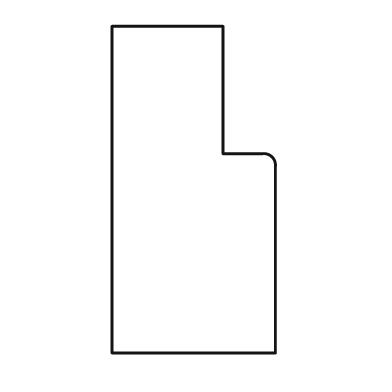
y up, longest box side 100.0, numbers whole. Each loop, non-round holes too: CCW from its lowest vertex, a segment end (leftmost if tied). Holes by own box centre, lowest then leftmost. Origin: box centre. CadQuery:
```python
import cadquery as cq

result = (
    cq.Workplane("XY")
    .moveTo(-25.0, -50.0)
    .lineTo(25.0, -50.0)
    .lineTo(25.0, 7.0)
    .threePointArc((24.0, 10.0), (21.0, 11.0))
    .lineTo(9.0, 11.0)
    .lineTo(9.0, 50.0)
    .lineTo(-25.0, 50.0)
    .close()
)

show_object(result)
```